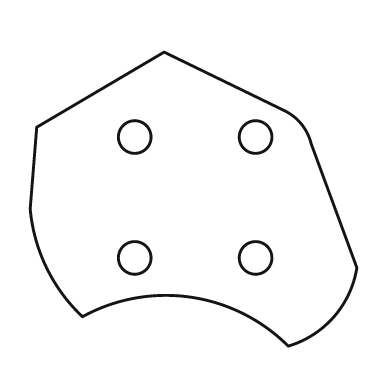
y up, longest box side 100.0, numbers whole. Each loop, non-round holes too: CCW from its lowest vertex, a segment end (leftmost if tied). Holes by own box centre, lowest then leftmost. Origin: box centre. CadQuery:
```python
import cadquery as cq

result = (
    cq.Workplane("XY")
    .moveTo(29.0, -45.0)
    .threePointArc((43.0, -36.0), (50.0, -21.0))
    .lineTo(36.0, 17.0)
    .threePointArc((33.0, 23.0), (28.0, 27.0))
    .lineTo(-9.0, 45.0)
    .lineTo(-48.0, 22.0)
    .lineTo(-50.0, -3.0)
    .threePointArc((-45.0, -21.0), (-34.0, -36.0))
    .threePointArc((-1.0, -30.0), (29.0, -45.0))
    .close()
    .moveTo(-18.0, -18.0)
    .circle(5.0)
    .moveTo(19.0, -18.0)
    .circle(5.0)
    .moveTo(-18.0, 19.0)
    .circle(5.0)
    .moveTo(19.0, 19.0)
    .circle(5.0)
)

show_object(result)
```